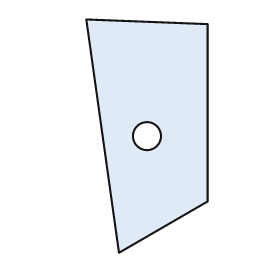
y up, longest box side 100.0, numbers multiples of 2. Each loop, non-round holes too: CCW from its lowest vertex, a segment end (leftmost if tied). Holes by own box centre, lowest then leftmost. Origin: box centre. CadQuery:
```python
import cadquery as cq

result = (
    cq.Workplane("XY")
    .moveTo(-12.0, -50.0)
    .lineTo(26.0, -28.0)
    .lineTo(26.0, 48.0)
    .lineTo(-26.0, 50.0)
    .close()
    .moveTo(0.0, 0.0)
    .circle(6.0)
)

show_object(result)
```